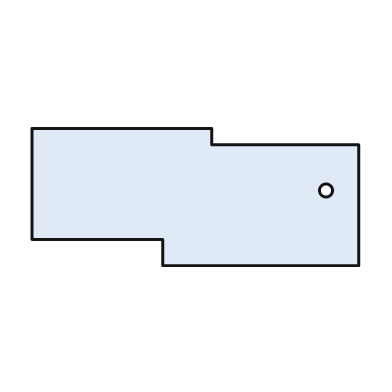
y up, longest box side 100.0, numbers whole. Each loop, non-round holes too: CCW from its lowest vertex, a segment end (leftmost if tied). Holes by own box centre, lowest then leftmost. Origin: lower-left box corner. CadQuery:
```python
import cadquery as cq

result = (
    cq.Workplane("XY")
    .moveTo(40.0, 0.0)
    .lineTo(100.0, 0.0)
    .lineTo(100.0, 37.0)
    .lineTo(55.0, 37.0)
    .lineTo(55.0, 42.0)
    .lineTo(0.0, 42.0)
    .lineTo(0.0, 8.0)
    .lineTo(40.0, 8.0)
    .close()
    .moveTo(90.0, 23.0)
    .circle(2.0)
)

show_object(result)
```